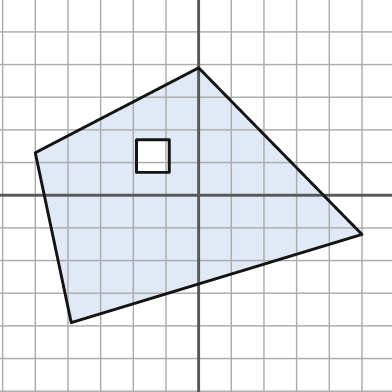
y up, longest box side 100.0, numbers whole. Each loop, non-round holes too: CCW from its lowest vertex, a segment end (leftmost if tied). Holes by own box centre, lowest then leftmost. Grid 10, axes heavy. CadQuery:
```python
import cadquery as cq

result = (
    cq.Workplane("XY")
    .moveTo(-39.0, -39.0)
    .lineTo(50.0, -12.0)
    .lineTo(0.0, 39.0)
    .lineTo(-50.0, 13.0)
    .close()
    .moveTo(-19.0, 7.0)
    .lineTo(-9.0, 7.0)
    .lineTo(-9.0, 17.0)
    .lineTo(-19.0, 17.0)
    .close()
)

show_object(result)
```